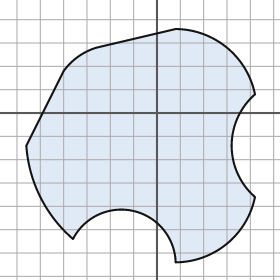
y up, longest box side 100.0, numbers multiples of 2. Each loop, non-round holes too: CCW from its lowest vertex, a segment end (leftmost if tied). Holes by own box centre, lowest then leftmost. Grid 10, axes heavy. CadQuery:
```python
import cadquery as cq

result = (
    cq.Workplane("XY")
    .moveTo(8.0, -64.0)
    .threePointArc((30.0, -56.0), (42.0, -36.0))
    .threePointArc((32.0, -14.0), (42.0, 8.0))
    .threePointArc((30.0, 28.0), (8.0, 36.0))
    .lineTo(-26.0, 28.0)
    .threePointArc((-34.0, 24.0), (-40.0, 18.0))
    .lineTo(-56.0, -14.0)
    .threePointArc((-50.0, -36.0), (-36.0, -54.0))
    .threePointArc((-10.0, -42.0), (8.0, -64.0))
    .close()
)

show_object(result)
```